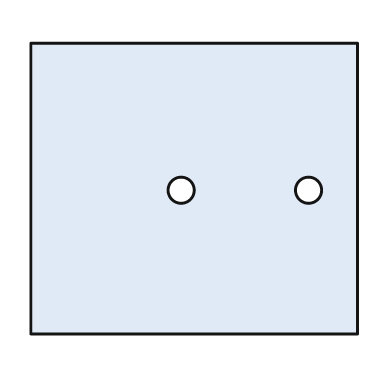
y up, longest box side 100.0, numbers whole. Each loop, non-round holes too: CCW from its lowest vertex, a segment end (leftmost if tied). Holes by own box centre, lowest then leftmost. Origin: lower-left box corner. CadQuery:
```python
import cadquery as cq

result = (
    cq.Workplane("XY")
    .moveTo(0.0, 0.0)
    .lineTo(100.0, 0.0)
    .lineTo(100.0, 89.0)
    .lineTo(0.0, 89.0)
    .close()
    .moveTo(46.0, 44.0)
    .circle(4.0)
    .moveTo(85.0, 44.0)
    .circle(4.0)
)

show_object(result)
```